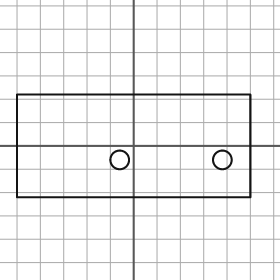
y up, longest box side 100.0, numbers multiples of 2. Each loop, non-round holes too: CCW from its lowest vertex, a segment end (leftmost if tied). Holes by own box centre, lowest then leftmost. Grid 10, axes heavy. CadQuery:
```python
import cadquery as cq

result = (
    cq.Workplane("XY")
    .moveTo(-50.0, -22.0)
    .lineTo(50.0, -22.0)
    .lineTo(50.0, 22.0)
    .lineTo(-50.0, 22.0)
    .close()
    .moveTo(-6.0, -6.0)
    .circle(4.0)
    .moveTo(38.0, -6.0)
    .circle(4.0)
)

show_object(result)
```